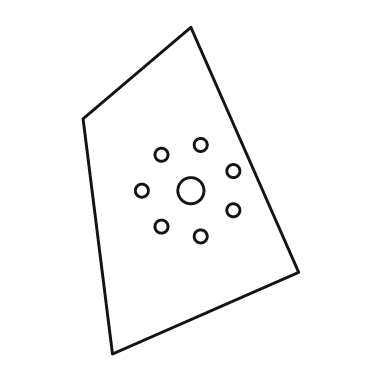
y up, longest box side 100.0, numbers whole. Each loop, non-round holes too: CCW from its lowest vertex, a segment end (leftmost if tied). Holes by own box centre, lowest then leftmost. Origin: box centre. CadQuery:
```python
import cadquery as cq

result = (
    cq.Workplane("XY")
    .moveTo(-24.0, -50.0)
    .lineTo(33.0, -25.0)
    .lineTo(0.0, 50.0)
    .lineTo(-33.0, 22.0)
    .close()
    .moveTo(3.0, -14.0)
    .circle(2.0)
    .moveTo(-9.0, -11.0)
    .circle(2.0)
    .moveTo(13.0, -6.0)
    .circle(2.0)
    .moveTo(-15.0, 0.0)
    .circle(2.0)
    .moveTo(0.0, 0.0)
    .circle(4.0)
    .moveTo(13.0, 6.0)
    .circle(2.0)
    .moveTo(-9.0, 11.0)
    .circle(2.0)
    .moveTo(3.0, 14.0)
    .circle(2.0)
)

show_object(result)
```